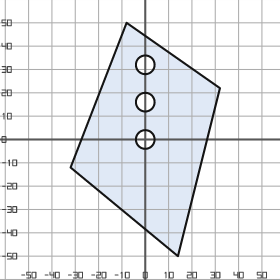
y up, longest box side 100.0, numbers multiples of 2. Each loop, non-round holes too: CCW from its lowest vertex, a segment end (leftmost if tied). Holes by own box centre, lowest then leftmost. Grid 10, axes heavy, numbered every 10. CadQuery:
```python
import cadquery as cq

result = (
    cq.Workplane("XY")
    .moveTo(14.0, -50.0)
    .lineTo(32.0, 22.0)
    .lineTo(-8.0, 50.0)
    .lineTo(-32.0, -12.0)
    .close()
    .moveTo(0.0, 0.0)
    .circle(4.0)
    .moveTo(0.0, 16.0)
    .circle(4.0)
    .moveTo(0.0, 32.0)
    .circle(4.0)
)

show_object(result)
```